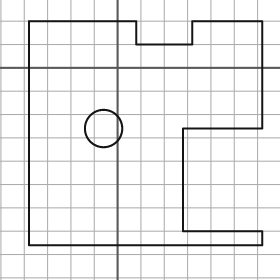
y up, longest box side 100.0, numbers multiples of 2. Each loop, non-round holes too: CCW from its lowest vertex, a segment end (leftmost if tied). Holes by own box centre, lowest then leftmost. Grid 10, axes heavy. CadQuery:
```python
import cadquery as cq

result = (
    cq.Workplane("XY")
    .moveTo(-38.0, -76.0)
    .lineTo(62.0, -76.0)
    .lineTo(62.0, -70.0)
    .lineTo(28.0, -70.0)
    .lineTo(28.0, -26.0)
    .lineTo(62.0, -26.0)
    .lineTo(62.0, 20.0)
    .lineTo(32.0, 20.0)
    .lineTo(32.0, 10.0)
    .lineTo(8.0, 10.0)
    .lineTo(8.0, 20.0)
    .lineTo(-38.0, 20.0)
    .close()
    .moveTo(-6.0, -26.0)
    .circle(8.0)
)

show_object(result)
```